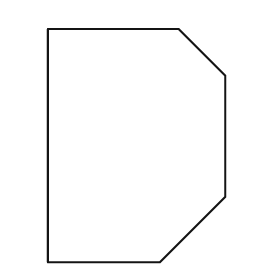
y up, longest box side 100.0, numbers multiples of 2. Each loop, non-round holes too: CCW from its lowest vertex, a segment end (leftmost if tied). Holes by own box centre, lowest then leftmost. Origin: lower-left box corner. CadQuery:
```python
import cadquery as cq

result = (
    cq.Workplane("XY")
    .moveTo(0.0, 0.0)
    .lineTo(48.0, 0.0)
    .lineTo(76.0, 28.0)
    .lineTo(76.0, 80.0)
    .lineTo(56.0, 100.0)
    .lineTo(0.0, 100.0)
    .close()
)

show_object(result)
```